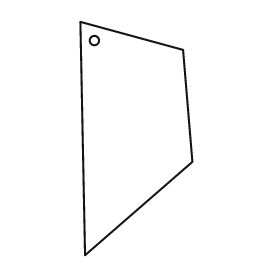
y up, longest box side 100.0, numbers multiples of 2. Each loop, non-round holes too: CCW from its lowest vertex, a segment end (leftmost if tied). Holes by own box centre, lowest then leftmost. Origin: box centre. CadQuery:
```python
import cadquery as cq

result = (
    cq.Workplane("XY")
    .moveTo(-22.0, -50.0)
    .lineTo(24.0, -10.0)
    .lineTo(20.0, 38.0)
    .lineTo(-24.0, 50.0)
    .close()
    .moveTo(-18.0, 42.0)
    .circle(2.0)
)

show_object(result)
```